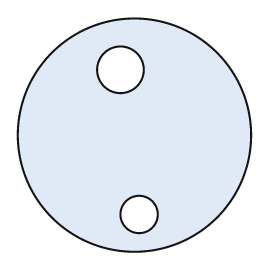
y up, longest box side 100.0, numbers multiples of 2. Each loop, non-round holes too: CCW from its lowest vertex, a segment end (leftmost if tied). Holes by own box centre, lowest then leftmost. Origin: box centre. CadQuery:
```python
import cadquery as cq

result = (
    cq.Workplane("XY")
    .moveTo(0.0, 0.0)
    .circle(50.0)
    .moveTo(2.0, -34.0)
    .circle(8.0)
    .moveTo(-6.0, 28.0)
    .circle(10.0)
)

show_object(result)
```